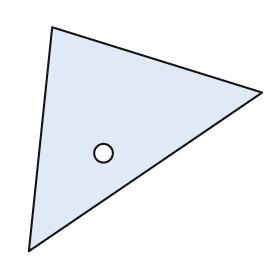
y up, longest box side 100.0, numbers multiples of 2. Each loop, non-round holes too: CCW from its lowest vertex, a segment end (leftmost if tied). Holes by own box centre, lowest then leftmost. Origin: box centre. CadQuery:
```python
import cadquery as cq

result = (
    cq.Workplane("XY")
    .moveTo(-50.0, -48.0)
    .lineTo(50.0, 20.0)
    .lineTo(-40.0, 48.0)
    .close()
    .moveTo(-18.0, -6.0)
    .circle(4.0)
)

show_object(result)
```